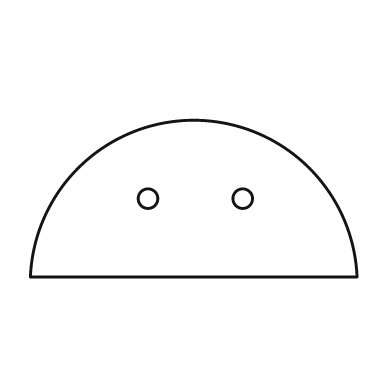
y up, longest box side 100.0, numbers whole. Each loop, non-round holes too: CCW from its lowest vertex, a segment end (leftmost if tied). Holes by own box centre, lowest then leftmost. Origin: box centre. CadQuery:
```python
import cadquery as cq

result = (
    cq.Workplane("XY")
    .moveTo(-50.0, -24.0)
    .lineTo(50.0, -24.0)
    .threePointArc((0.0, 24.0), (-50.0, -24.0))
    .close()
    .moveTo(-14.0, 0.0)
    .circle(3.0)
    .moveTo(15.0, 0.0)
    .circle(3.0)
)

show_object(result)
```